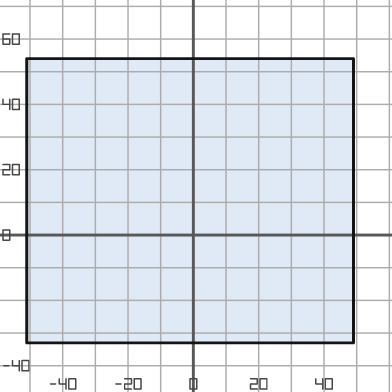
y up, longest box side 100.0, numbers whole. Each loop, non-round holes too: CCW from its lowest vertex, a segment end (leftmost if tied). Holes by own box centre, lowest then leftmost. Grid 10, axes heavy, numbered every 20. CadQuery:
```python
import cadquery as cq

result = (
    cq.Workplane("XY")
    .moveTo(-51.0, -33.0)
    .lineTo(49.0, -33.0)
    .lineTo(49.0, 54.0)
    .lineTo(-51.0, 54.0)
    .close()
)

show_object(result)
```